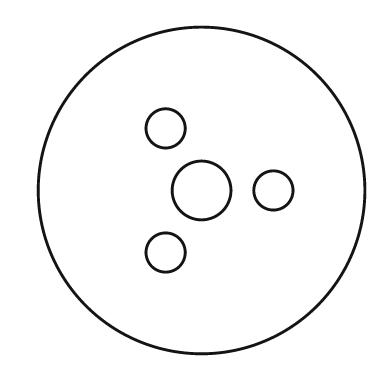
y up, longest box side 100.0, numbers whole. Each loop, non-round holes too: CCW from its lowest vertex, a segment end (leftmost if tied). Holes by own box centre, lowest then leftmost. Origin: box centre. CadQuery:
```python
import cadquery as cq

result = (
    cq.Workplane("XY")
    .moveTo(0.0, 0.0)
    .circle(50.0)
    .moveTo(-11.0, -19.0)
    .circle(6.0)
    .moveTo(0.0, 0.0)
    .circle(9.0)
    .moveTo(22.0, 0.0)
    .circle(6.0)
    .moveTo(-11.0, 19.0)
    .circle(6.0)
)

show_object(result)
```